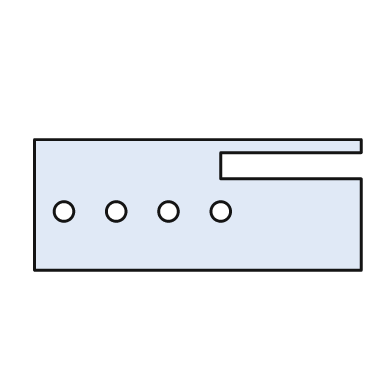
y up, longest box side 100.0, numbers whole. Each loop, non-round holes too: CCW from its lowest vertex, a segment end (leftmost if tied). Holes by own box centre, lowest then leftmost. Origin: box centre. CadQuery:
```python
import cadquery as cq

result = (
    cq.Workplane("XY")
    .moveTo(-50.0, -20.0)
    .lineTo(50.0, -20.0)
    .lineTo(50.0, 8.0)
    .lineTo(7.0, 8.0)
    .lineTo(7.0, 16.0)
    .lineTo(50.0, 16.0)
    .lineTo(50.0, 20.0)
    .lineTo(-50.0, 20.0)
    .close()
    .moveTo(-41.0, -2.0)
    .circle(3.0)
    .moveTo(-25.0, -2.0)
    .circle(3.0)
    .moveTo(-9.0, -2.0)
    .circle(3.0)
    .moveTo(7.0, -2.0)
    .circle(3.0)
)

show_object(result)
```